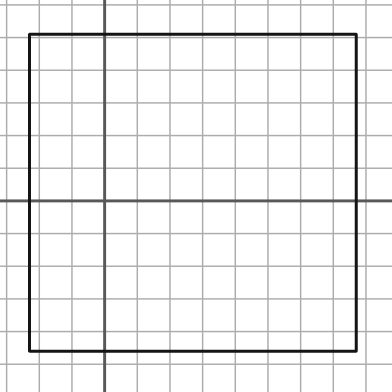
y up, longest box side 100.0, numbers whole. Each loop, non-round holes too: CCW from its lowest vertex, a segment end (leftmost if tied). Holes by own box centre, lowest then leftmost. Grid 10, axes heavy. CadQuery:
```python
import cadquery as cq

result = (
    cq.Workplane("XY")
    .moveTo(-23.0, -46.0)
    .lineTo(77.0, -46.0)
    .lineTo(77.0, 51.0)
    .lineTo(-23.0, 51.0)
    .close()
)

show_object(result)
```